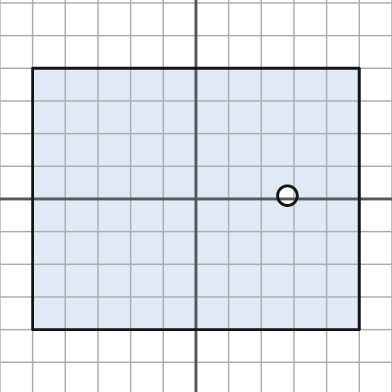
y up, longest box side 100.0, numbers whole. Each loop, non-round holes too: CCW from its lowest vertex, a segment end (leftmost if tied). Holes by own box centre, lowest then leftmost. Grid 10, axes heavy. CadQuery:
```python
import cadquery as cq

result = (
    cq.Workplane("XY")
    .moveTo(-50.0, -40.0)
    .lineTo(50.0, -40.0)
    .lineTo(50.0, 40.0)
    .lineTo(-50.0, 40.0)
    .close()
    .moveTo(28.0, 1.0)
    .circle(3.0)
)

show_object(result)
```